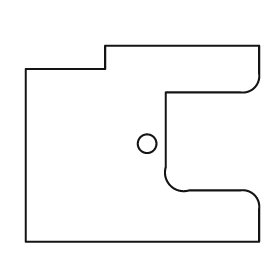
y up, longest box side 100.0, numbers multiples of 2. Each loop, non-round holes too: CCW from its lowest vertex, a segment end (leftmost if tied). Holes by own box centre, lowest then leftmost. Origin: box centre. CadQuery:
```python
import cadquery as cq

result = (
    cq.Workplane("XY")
    .moveTo(-50.0, -42.0)
    .lineTo(50.0, -42.0)
    .lineTo(50.0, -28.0)
    .threePointArc((48.0, -22.0), (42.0, -20.0))
    .lineTo(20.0, -20.0)
    .threePointArc((12.0, -18.0), (10.0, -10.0))
    .lineTo(10.0, 22.0)
    .lineTo(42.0, 22.0)
    .threePointArc((48.0, 24.0), (50.0, 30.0))
    .lineTo(50.0, 42.0)
    .lineTo(-16.0, 42.0)
    .lineTo(-16.0, 32.0)
    .lineTo(-50.0, 32.0)
    .close()
    .moveTo(2.0, 0.0)
    .circle(4.0)
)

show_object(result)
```